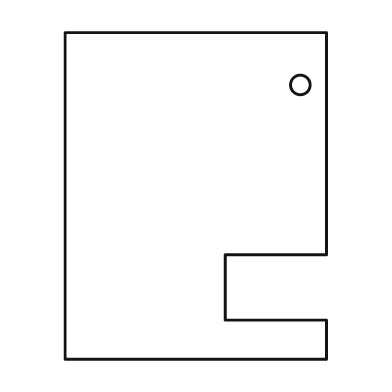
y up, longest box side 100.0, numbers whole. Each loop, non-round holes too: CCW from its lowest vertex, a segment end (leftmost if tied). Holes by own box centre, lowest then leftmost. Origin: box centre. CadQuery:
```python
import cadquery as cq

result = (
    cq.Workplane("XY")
    .moveTo(-40.0, -50.0)
    .lineTo(40.0, -50.0)
    .lineTo(40.0, -38.0)
    .lineTo(9.0, -38.0)
    .lineTo(9.0, -18.0)
    .lineTo(40.0, -18.0)
    .lineTo(40.0, 50.0)
    .lineTo(-40.0, 50.0)
    .close()
    .moveTo(32.0, 34.0)
    .circle(3.0)
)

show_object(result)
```